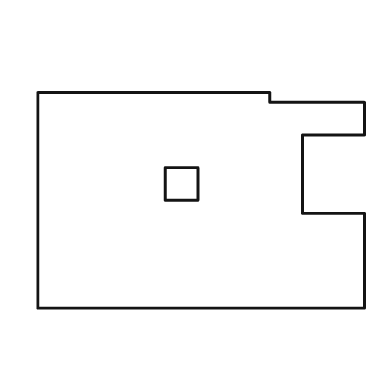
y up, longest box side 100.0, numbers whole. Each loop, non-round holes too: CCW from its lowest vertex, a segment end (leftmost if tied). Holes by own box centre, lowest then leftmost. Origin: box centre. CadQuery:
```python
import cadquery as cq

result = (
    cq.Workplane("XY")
    .moveTo(-50.0, -33.0)
    .lineTo(50.0, -33.0)
    .lineTo(50.0, -4.0)
    .lineTo(31.0, -4.0)
    .lineTo(31.0, 20.0)
    .lineTo(50.0, 20.0)
    .lineTo(50.0, 30.0)
    .lineTo(21.0, 30.0)
    .lineTo(21.0, 33.0)
    .lineTo(-50.0, 33.0)
    .close()
    .moveTo(-11.0, 0.0)
    .lineTo(-1.0, 0.0)
    .lineTo(-1.0, 10.0)
    .lineTo(-11.0, 10.0)
    .close()
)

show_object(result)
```